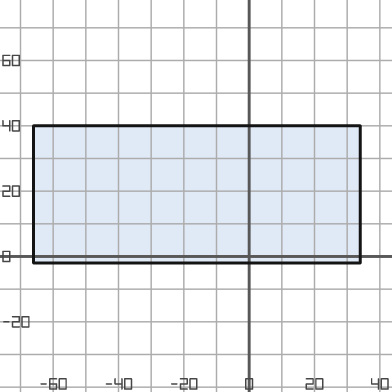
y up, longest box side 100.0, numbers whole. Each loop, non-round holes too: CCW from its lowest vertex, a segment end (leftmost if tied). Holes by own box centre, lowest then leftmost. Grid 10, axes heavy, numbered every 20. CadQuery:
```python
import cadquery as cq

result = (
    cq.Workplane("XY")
    .moveTo(-66.0, -2.0)
    .lineTo(34.0, -2.0)
    .lineTo(34.0, 40.0)
    .lineTo(-66.0, 40.0)
    .close()
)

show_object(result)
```